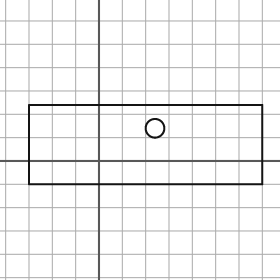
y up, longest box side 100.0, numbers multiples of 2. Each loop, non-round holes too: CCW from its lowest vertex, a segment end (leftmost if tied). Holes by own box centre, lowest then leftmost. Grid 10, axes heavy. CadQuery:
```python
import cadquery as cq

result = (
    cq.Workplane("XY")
    .moveTo(-30.0, -10.0)
    .lineTo(70.0, -10.0)
    .lineTo(70.0, 24.0)
    .lineTo(-30.0, 24.0)
    .close()
    .moveTo(24.0, 14.0)
    .circle(4.0)
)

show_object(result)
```